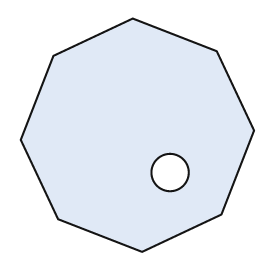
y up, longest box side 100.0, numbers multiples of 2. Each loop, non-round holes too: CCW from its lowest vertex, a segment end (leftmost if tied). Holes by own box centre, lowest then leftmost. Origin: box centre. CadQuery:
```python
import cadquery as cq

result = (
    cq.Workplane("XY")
    .moveTo(2.0, -50.0)
    .lineTo(36.0, -34.0)
    .lineTo(50.0, 2.0)
    .lineTo(34.0, 36.0)
    .lineTo(-2.0, 50.0)
    .lineTo(-36.0, 34.0)
    .lineTo(-50.0, -2.0)
    .lineTo(-34.0, -36.0)
    .close()
    .moveTo(14.0, -16.0)
    .circle(8.0)
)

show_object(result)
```